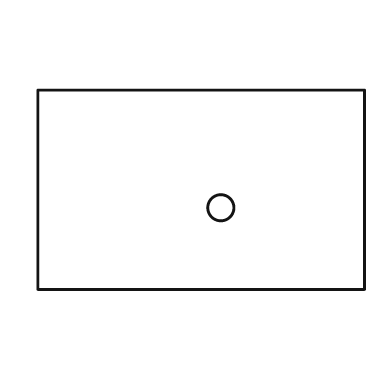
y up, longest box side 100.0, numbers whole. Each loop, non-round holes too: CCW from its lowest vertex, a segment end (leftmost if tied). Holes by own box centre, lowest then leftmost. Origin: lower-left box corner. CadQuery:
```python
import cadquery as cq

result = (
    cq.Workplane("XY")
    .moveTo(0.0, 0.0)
    .lineTo(100.0, 0.0)
    .lineTo(100.0, 61.0)
    .lineTo(0.0, 61.0)
    .close()
    .moveTo(56.0, 25.0)
    .circle(4.0)
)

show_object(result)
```